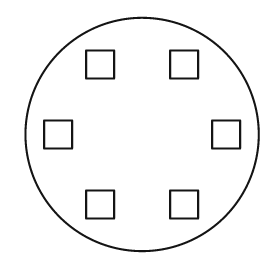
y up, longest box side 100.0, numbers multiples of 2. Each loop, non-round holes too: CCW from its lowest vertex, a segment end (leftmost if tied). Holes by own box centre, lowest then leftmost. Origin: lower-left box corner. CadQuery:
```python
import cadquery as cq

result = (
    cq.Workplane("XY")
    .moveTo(50.0, 50.0)
    .circle(50.0)
    .moveTo(26.0, 14.0)
    .lineTo(38.0, 14.0)
    .lineTo(38.0, 26.0)
    .lineTo(26.0, 26.0)
    .close()
    .moveTo(62.0, 14.0)
    .lineTo(74.0, 14.0)
    .lineTo(74.0, 26.0)
    .lineTo(62.0, 26.0)
    .close()
    .moveTo(8.0, 44.0)
    .lineTo(20.0, 44.0)
    .lineTo(20.0, 56.0)
    .lineTo(8.0, 56.0)
    .close()
    .moveTo(80.0, 44.0)
    .lineTo(92.0, 44.0)
    .lineTo(92.0, 56.0)
    .lineTo(80.0, 56.0)
    .close()
    .moveTo(26.0, 74.0)
    .lineTo(38.0, 74.0)
    .lineTo(38.0, 86.0)
    .lineTo(26.0, 86.0)
    .close()
    .moveTo(62.0, 74.0)
    .lineTo(74.0, 74.0)
    .lineTo(74.0, 86.0)
    .lineTo(62.0, 86.0)
    .close()
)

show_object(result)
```